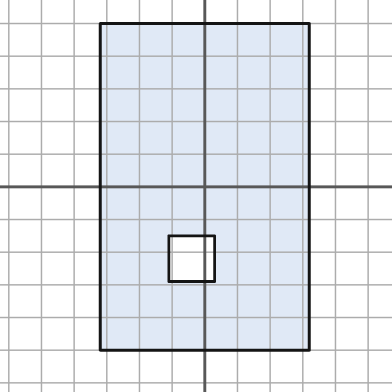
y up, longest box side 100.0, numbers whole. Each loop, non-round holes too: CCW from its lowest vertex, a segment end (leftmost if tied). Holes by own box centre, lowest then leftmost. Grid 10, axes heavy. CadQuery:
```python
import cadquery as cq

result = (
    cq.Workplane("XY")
    .moveTo(-32.0, -50.0)
    .lineTo(32.0, -50.0)
    .lineTo(32.0, 50.0)
    .lineTo(-32.0, 50.0)
    .close()
    .moveTo(-11.0, -29.0)
    .lineTo(3.0, -29.0)
    .lineTo(3.0, -15.0)
    .lineTo(-11.0, -15.0)
    .close()
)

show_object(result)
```